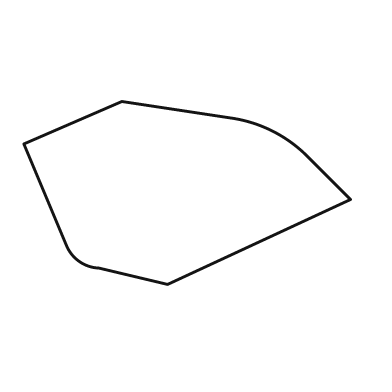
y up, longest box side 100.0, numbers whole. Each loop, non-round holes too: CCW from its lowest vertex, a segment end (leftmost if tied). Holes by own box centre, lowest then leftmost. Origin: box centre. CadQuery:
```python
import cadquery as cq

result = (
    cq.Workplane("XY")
    .moveTo(-6.0, -28.0)
    .lineTo(50.0, -2.0)
    .lineTo(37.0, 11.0)
    .threePointArc((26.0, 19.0), (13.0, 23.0))
    .lineTo(-20.0, 28.0)
    .lineTo(-50.0, 15.0)
    .lineTo(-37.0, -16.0)
    .threePointArc((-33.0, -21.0), (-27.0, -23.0))
    .close()
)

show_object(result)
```